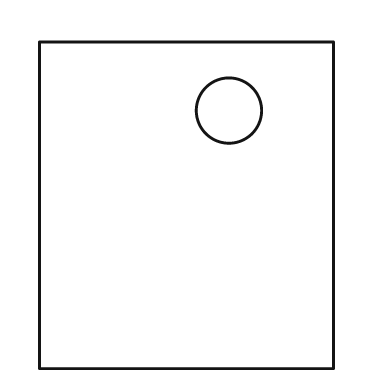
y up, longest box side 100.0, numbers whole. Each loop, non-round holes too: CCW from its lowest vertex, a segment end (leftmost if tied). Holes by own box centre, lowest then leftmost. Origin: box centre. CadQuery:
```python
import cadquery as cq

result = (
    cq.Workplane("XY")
    .moveTo(-45.0, -50.0)
    .lineTo(45.0, -50.0)
    .lineTo(45.0, 50.0)
    .lineTo(-45.0, 50.0)
    .close()
    .moveTo(13.0, 29.0)
    .circle(10.0)
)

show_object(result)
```